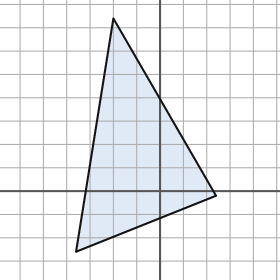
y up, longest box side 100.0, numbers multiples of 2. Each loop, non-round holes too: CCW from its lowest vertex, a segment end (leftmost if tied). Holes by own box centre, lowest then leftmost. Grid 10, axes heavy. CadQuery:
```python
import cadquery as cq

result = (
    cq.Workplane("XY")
    .moveTo(-36.0, -26.0)
    .lineTo(24.0, -2.0)
    .lineTo(-20.0, 74.0)
    .close()
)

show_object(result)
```